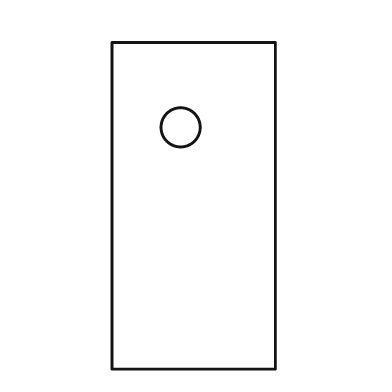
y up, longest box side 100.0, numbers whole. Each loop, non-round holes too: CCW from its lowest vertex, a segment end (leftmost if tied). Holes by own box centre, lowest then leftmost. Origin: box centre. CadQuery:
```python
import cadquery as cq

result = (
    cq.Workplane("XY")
    .moveTo(-25.0, -50.0)
    .lineTo(25.0, -50.0)
    .lineTo(25.0, 50.0)
    .lineTo(-25.0, 50.0)
    .close()
    .moveTo(-4.0, 24.0)
    .circle(6.0)
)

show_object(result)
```